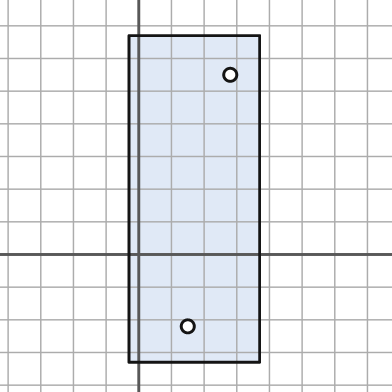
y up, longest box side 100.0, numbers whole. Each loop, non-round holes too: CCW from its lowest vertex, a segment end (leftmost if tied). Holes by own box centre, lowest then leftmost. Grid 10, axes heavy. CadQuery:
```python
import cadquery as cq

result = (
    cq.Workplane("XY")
    .moveTo(-3.0, -33.0)
    .lineTo(37.0, -33.0)
    .lineTo(37.0, 67.0)
    .lineTo(-3.0, 67.0)
    .close()
    .moveTo(15.0, -22.0)
    .circle(2.0)
    .moveTo(28.0, 55.0)
    .circle(2.0)
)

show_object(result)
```